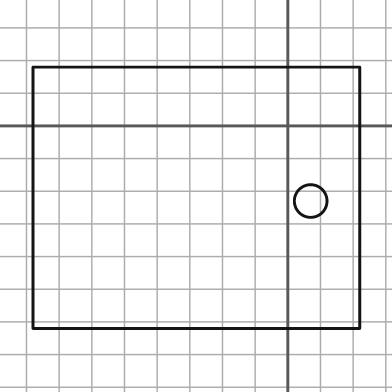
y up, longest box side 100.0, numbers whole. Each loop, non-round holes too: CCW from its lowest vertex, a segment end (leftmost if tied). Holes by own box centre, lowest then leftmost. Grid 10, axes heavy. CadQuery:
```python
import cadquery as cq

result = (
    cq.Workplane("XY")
    .moveTo(-78.0, -62.0)
    .lineTo(22.0, -62.0)
    .lineTo(22.0, 18.0)
    .lineTo(-78.0, 18.0)
    .close()
    .moveTo(7.0, -23.0)
    .circle(5.0)
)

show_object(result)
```